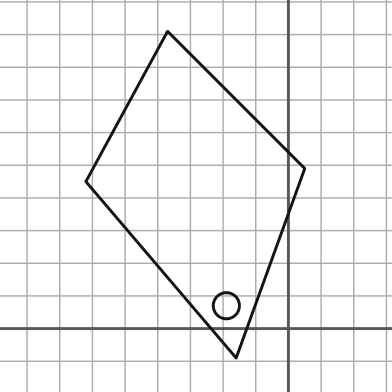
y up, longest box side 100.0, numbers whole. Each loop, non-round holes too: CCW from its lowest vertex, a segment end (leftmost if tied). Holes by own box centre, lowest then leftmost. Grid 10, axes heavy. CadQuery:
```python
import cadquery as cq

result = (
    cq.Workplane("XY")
    .moveTo(-16.0, -9.0)
    .lineTo(5.0, 49.0)
    .lineTo(-37.0, 91.0)
    .lineTo(-62.0, 45.0)
    .close()
    .moveTo(-19.0, 7.0)
    .circle(4.0)
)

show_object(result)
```